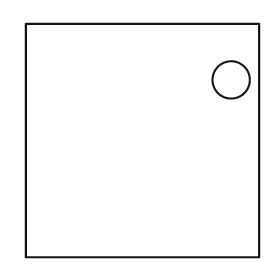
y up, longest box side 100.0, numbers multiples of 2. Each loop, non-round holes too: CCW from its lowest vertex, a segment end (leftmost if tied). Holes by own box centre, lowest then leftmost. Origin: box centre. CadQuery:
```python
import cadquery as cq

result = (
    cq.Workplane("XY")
    .moveTo(-50.0, -50.0)
    .lineTo(50.0, -50.0)
    .lineTo(50.0, 50.0)
    .lineTo(-50.0, 50.0)
    .close()
    .moveTo(38.0, 26.0)
    .circle(8.0)
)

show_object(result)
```